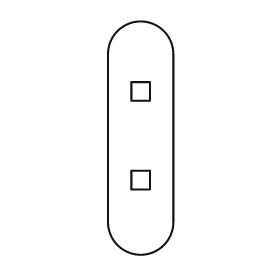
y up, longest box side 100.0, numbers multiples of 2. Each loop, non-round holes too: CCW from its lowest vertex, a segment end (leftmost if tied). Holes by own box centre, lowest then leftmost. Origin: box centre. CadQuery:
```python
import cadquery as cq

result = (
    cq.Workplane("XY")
    .moveTo(-14.0, -36.0)
    .threePointArc((0.0, -50.0), (14.0, -36.0))
    .lineTo(14.0, 36.0)
    .threePointArc((0.0, 50.0), (-14.0, 36.0))
    .close()
    .moveTo(-4.0, -22.0)
    .lineTo(4.0, -22.0)
    .lineTo(4.0, -14.0)
    .lineTo(-4.0, -14.0)
    .close()
    .moveTo(-4.0, 16.0)
    .lineTo(4.0, 16.0)
    .lineTo(4.0, 24.0)
    .lineTo(-4.0, 24.0)
    .close()
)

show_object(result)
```